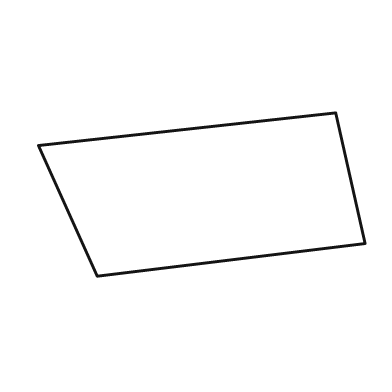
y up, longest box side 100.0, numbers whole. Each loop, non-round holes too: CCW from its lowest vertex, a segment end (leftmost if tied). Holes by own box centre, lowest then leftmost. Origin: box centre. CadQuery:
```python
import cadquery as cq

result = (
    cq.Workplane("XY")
    .moveTo(-32.0, -25.0)
    .lineTo(50.0, -15.0)
    .lineTo(41.0, 25.0)
    .lineTo(-50.0, 15.0)
    .close()
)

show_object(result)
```